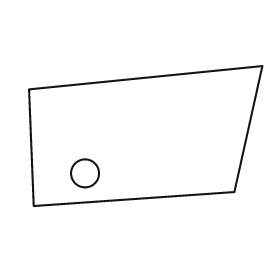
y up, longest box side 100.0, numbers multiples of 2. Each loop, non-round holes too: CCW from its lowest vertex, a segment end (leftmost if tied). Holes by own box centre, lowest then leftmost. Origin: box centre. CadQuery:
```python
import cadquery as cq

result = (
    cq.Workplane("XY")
    .moveTo(-48.0, -30.0)
    .lineTo(38.0, -24.0)
    .lineTo(50.0, 30.0)
    .lineTo(-50.0, 20.0)
    .close()
    .moveTo(-26.0, -16.0)
    .circle(6.0)
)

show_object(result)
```